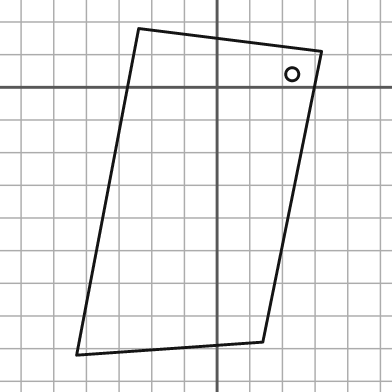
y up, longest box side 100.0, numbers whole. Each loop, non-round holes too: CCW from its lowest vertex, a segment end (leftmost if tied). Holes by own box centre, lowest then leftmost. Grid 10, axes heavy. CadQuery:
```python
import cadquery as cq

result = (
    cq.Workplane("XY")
    .moveTo(-43.0, -82.0)
    .lineTo(14.0, -78.0)
    .lineTo(32.0, 11.0)
    .lineTo(-24.0, 18.0)
    .close()
    .moveTo(23.0, 4.0)
    .circle(2.0)
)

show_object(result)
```